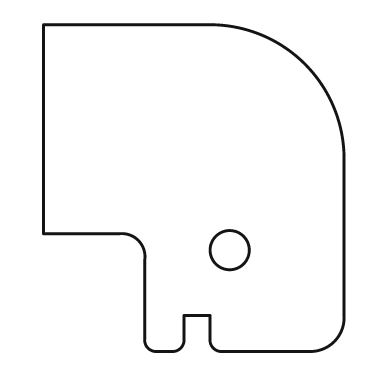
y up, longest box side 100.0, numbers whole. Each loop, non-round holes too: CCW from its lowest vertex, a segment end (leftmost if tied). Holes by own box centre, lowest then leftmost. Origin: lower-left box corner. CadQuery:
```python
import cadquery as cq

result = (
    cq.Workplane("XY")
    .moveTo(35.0, 0.0)
    .lineTo(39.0, 0.0)
    .threePointArc((42.0, 1.0), (43.0, 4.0))
    .lineTo(43.0, 11.0)
    .lineTo(51.0, 11.0)
    .lineTo(51.0, 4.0)
    .threePointArc((52.0, 1.0), (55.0, 0.0))
    .lineTo(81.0, 0.0)
    .threePointArc((89.0, 3.0), (92.0, 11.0))
    .lineTo(92.0, 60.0)
    .threePointArc((80.0, 88.0), (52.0, 100.0))
    .lineTo(0.0, 100.0)
    .lineTo(0.0, 36.0)
    .lineTo(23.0, 36.0)
    .threePointArc((29.0, 34.0), (31.0, 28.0))
    .lineTo(31.0, 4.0)
    .threePointArc((32.0, 1.0), (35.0, 0.0))
    .close()
    .moveTo(57.0, 31.0)
    .circle(6.0)
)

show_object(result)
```